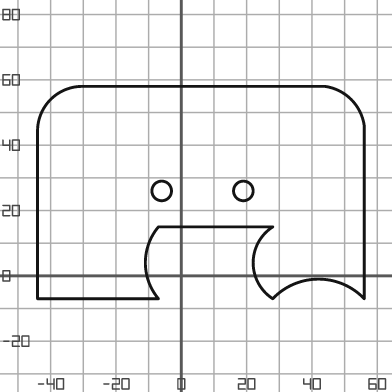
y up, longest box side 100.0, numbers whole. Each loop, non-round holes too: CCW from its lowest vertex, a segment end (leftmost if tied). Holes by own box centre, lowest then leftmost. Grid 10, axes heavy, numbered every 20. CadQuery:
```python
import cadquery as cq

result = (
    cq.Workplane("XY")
    .moveTo(-44.0, -7.0)
    .lineTo(-7.0, -7.0)
    .threePointArc((-11.0, 4.0), (-7.0, 15.0))
    .lineTo(28.0, 15.0)
    .threePointArc((22.0, 4.0), (28.0, -7.0))
    .threePointArc((42.0, -1.0), (56.0, -7.0))
    .lineTo(56.0, 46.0)
    .threePointArc((52.0, 54.0), (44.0, 58.0))
    .lineTo(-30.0, 58.0)
    .threePointArc((-40.0, 54.0), (-44.0, 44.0))
    .close()
    .moveTo(-6.0, 26.0)
    .circle(3.0)
    .moveTo(19.0, 26.0)
    .circle(3.0)
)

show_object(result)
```